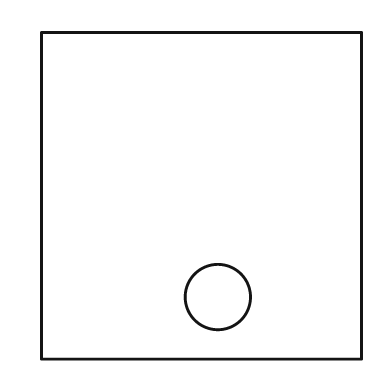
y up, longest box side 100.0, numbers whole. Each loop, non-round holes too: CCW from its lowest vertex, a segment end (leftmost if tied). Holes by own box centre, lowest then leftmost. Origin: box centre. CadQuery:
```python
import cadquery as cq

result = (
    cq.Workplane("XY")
    .moveTo(-49.0, -50.0)
    .lineTo(49.0, -50.0)
    .lineTo(49.0, 50.0)
    .lineTo(-49.0, 50.0)
    .close()
    .moveTo(5.0, -31.0)
    .circle(10.0)
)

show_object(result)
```